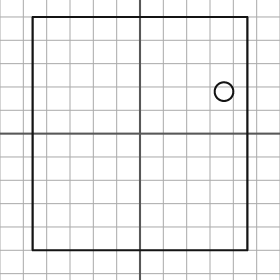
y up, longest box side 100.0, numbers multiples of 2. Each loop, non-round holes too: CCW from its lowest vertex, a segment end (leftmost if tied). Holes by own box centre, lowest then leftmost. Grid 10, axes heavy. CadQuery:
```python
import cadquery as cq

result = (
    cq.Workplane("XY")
    .moveTo(-46.0, -50.0)
    .lineTo(46.0, -50.0)
    .lineTo(46.0, 50.0)
    .lineTo(-46.0, 50.0)
    .close()
    .moveTo(36.0, 18.0)
    .circle(4.0)
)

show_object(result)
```